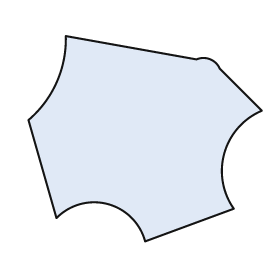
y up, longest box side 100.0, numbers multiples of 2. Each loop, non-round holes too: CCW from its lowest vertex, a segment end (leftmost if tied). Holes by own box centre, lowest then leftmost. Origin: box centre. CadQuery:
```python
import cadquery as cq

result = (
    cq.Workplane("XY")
    .moveTo(0.0, -44.0)
    .lineTo(38.0, -30.0)
    .threePointArc((34.0, -6.0), (50.0, 12.0))
    .lineTo(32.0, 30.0)
    .threePointArc((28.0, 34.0), (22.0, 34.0))
    .lineTo(-34.0, 44.0)
    .threePointArc((-38.0, 24.0), (-50.0, 8.0))
    .lineTo(-38.0, -34.0)
    .threePointArc((-16.0, -28.0), (0.0, -44.0))
    .close()
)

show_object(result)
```